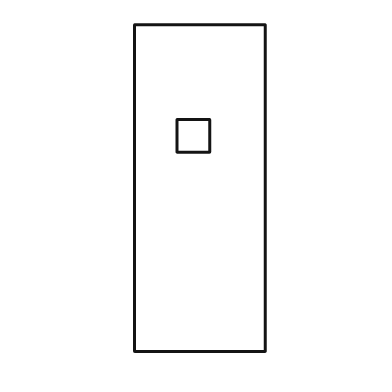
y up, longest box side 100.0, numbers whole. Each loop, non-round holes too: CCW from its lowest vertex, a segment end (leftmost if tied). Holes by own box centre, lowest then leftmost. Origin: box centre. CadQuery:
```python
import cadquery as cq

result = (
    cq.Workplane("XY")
    .moveTo(-20.0, -50.0)
    .lineTo(20.0, -50.0)
    .lineTo(20.0, 50.0)
    .lineTo(-20.0, 50.0)
    .close()
    .moveTo(-7.0, 11.0)
    .lineTo(3.0, 11.0)
    .lineTo(3.0, 21.0)
    .lineTo(-7.0, 21.0)
    .close()
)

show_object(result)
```